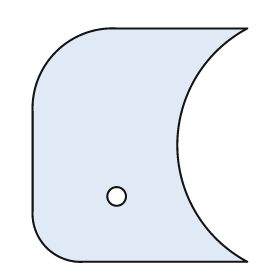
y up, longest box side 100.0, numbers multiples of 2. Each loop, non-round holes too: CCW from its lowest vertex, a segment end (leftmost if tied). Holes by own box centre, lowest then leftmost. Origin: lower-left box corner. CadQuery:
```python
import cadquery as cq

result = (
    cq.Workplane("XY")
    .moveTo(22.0, 0.0)
    .lineTo(92.0, 0.0)
    .threePointArc((62.0, 50.0), (92.0, 100.0))
    .lineTo(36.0, 100.0)
    .threePointArc((10.0, 90.0), (0.0, 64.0))
    .lineTo(0.0, 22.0)
    .threePointArc((6.0, 6.0), (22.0, 0.0))
    .close()
    .moveTo(36.0, 28.0)
    .circle(4.0)
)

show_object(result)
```